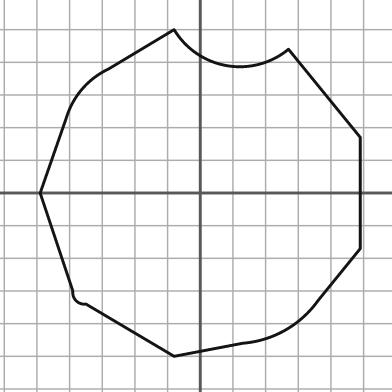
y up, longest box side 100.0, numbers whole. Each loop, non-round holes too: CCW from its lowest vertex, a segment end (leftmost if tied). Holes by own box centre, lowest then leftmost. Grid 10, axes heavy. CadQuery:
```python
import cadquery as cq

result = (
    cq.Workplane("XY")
    .moveTo(-8.0, -50.0)
    .lineTo(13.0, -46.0)
    .threePointArc((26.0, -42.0), (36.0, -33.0))
    .lineTo(49.0, -17.0)
    .lineTo(49.0, 17.0)
    .lineTo(27.0, 44.0)
    .threePointArc((8.0, 39.0), (-8.0, 50.0))
    .lineTo(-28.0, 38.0)
    .threePointArc((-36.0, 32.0), (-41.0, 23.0))
    .lineTo(-49.0, 0.0)
    .lineTo(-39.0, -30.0)
    .threePointArc((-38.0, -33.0), (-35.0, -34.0))
    .close()
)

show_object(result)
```